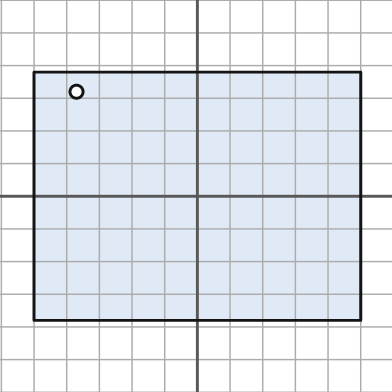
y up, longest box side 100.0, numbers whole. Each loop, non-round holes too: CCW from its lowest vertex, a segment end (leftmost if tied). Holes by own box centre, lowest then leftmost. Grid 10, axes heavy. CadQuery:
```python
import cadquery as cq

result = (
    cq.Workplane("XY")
    .moveTo(-50.0, -38.0)
    .lineTo(50.0, -38.0)
    .lineTo(50.0, 38.0)
    .lineTo(-50.0, 38.0)
    .close()
    .moveTo(-37.0, 32.0)
    .circle(2.0)
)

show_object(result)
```